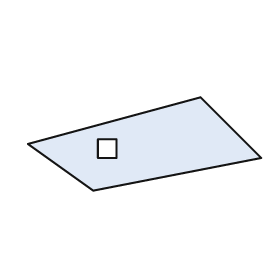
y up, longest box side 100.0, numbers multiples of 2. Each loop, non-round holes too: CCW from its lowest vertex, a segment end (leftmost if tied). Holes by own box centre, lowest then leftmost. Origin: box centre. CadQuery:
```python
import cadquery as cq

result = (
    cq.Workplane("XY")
    .moveTo(-22.0, -20.0)
    .lineTo(50.0, -6.0)
    .lineTo(24.0, 20.0)
    .lineTo(-50.0, 0.0)
    .close()
    .moveTo(-20.0, -6.0)
    .lineTo(-12.0, -6.0)
    .lineTo(-12.0, 2.0)
    .lineTo(-20.0, 2.0)
    .close()
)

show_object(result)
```